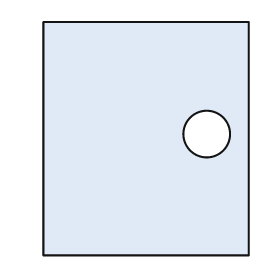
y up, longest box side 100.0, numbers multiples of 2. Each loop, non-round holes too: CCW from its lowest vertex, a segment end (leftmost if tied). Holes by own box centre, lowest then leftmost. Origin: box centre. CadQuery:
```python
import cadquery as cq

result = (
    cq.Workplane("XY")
    .moveTo(-44.0, -50.0)
    .lineTo(44.0, -50.0)
    .lineTo(44.0, 50.0)
    .lineTo(-44.0, 50.0)
    .close()
    .moveTo(26.0, 2.0)
    .circle(10.0)
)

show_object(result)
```